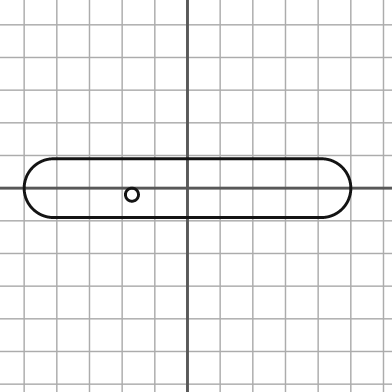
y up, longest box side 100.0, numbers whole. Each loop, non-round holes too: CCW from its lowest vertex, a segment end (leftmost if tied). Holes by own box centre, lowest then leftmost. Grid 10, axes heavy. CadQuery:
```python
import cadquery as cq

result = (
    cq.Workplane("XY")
    .moveTo(-41.0, -9.0)
    .lineTo(41.0, -9.0)
    .threePointArc((50.0, 0.0), (41.0, 9.0))
    .lineTo(-41.0, 9.0)
    .threePointArc((-50.0, 0.0), (-41.0, -9.0))
    .close()
    .moveTo(-17.0, -2.0)
    .circle(2.0)
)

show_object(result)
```